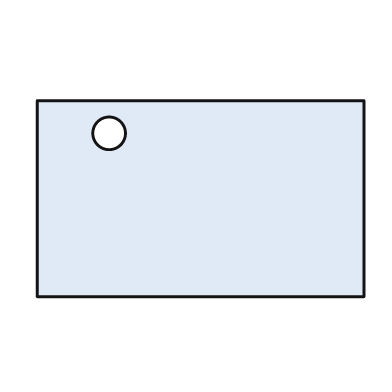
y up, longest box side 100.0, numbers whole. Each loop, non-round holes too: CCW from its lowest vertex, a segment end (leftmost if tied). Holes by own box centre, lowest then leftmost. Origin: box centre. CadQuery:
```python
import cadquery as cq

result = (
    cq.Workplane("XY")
    .moveTo(-50.0, -30.0)
    .lineTo(50.0, -30.0)
    .lineTo(50.0, 30.0)
    .lineTo(-50.0, 30.0)
    .close()
    .moveTo(-28.0, 20.0)
    .circle(5.0)
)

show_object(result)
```